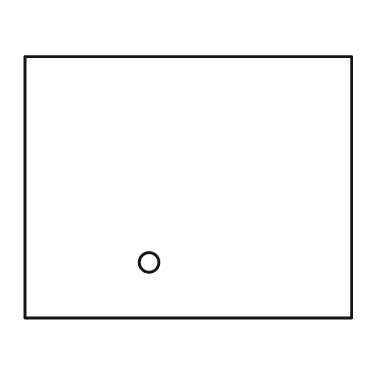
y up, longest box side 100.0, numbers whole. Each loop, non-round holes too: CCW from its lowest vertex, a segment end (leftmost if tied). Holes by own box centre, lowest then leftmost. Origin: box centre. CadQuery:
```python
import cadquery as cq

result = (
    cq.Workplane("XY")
    .moveTo(-50.0, -40.0)
    .lineTo(50.0, -40.0)
    .lineTo(50.0, 40.0)
    .lineTo(-50.0, 40.0)
    .close()
    .moveTo(-12.0, -23.0)
    .circle(3.0)
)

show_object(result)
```